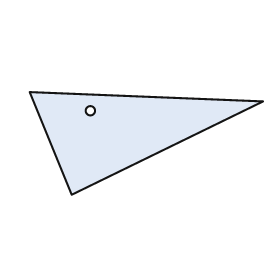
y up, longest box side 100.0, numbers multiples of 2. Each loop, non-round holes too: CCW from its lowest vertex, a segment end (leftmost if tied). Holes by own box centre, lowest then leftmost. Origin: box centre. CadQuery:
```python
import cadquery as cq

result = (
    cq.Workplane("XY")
    .moveTo(-32.0, -22.0)
    .lineTo(50.0, 18.0)
    .lineTo(-50.0, 22.0)
    .close()
    .moveTo(-24.0, 14.0)
    .circle(2.0)
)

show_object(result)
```